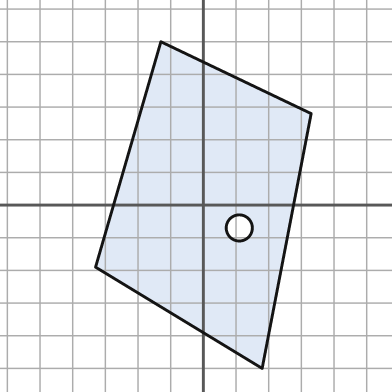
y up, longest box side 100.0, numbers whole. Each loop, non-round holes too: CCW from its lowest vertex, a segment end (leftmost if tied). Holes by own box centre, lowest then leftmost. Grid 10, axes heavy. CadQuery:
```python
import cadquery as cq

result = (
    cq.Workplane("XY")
    .moveTo(18.0, -50.0)
    .lineTo(33.0, 28.0)
    .lineTo(-13.0, 50.0)
    .lineTo(-33.0, -19.0)
    .close()
    .moveTo(11.0, -7.0)
    .circle(4.0)
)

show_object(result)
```